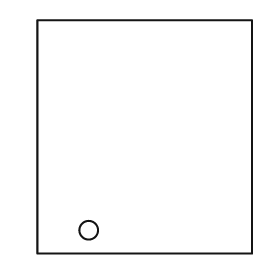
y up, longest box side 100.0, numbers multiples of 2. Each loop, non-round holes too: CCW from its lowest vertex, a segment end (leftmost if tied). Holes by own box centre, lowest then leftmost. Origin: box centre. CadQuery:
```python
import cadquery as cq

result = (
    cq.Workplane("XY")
    .moveTo(-46.0, -50.0)
    .lineTo(46.0, -50.0)
    .lineTo(46.0, 50.0)
    .lineTo(-46.0, 50.0)
    .close()
    .moveTo(-24.0, -40.0)
    .circle(4.0)
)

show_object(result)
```